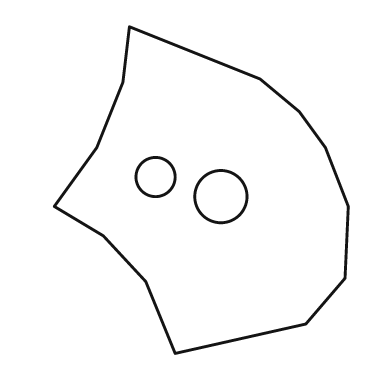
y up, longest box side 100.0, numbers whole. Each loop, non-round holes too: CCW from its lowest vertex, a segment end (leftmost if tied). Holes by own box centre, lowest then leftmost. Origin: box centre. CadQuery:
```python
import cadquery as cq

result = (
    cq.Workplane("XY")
    .moveTo(-8.0, -50.0)
    .lineTo(32.0, -41.0)
    .lineTo(44.0, -27.0)
    .lineTo(45.0, -5.0)
    .lineTo(38.0, 13.0)
    .lineTo(30.0, 24.0)
    .lineTo(18.0, 34.0)
    .lineTo(-22.0, 50.0)
    .lineTo(-24.0, 33.0)
    .lineTo(-32.0, 13.0)
    .lineTo(-45.0, -5.0)
    .lineTo(-30.0, -14.0)
    .lineTo(-17.0, -28.0)
    .close()
    .moveTo(6.0, -2.0)
    .circle(8.0)
    .moveTo(-14.0, 4.0)
    .circle(6.0)
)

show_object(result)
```